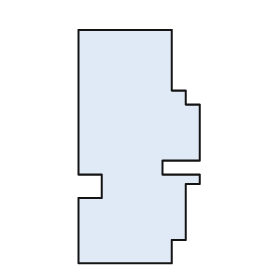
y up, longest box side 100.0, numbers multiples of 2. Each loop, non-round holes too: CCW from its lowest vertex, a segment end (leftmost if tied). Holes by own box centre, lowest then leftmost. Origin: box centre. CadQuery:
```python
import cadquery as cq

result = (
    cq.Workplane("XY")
    .moveTo(-26.0, -50.0)
    .lineTo(14.0, -50.0)
    .lineTo(14.0, -40.0)
    .lineTo(20.0, -40.0)
    .lineTo(20.0, -16.0)
    .lineTo(26.0, -16.0)
    .lineTo(26.0, -12.0)
    .lineTo(10.0, -12.0)
    .lineTo(10.0, -6.0)
    .lineTo(26.0, -6.0)
    .lineTo(26.0, 18.0)
    .lineTo(20.0, 18.0)
    .lineTo(20.0, 24.0)
    .lineTo(14.0, 24.0)
    .lineTo(14.0, 50.0)
    .lineTo(-26.0, 50.0)
    .lineTo(-26.0, -12.0)
    .lineTo(-16.0, -12.0)
    .lineTo(-16.0, -22.0)
    .lineTo(-26.0, -22.0)
    .close()
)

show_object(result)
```